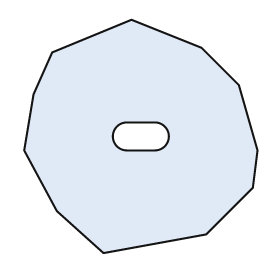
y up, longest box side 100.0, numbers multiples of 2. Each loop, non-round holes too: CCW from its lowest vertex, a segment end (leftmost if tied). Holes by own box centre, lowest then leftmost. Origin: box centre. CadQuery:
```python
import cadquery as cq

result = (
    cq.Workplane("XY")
    .moveTo(-16.0, -50.0)
    .lineTo(28.0, -42.0)
    .lineTo(48.0, -22.0)
    .lineTo(50.0, -6.0)
    .lineTo(42.0, 22.0)
    .lineTo(26.0, 38.0)
    .lineTo(-4.0, 50.0)
    .lineTo(-38.0, 36.0)
    .lineTo(-46.0, 18.0)
    .lineTo(-50.0, -6.0)
    .lineTo(-36.0, -32.0)
    .close()
    .moveTo(-6.0, -6.0)
    .lineTo(6.0, -6.0)
    .threePointArc((12.0, 0.0), (6.0, 6.0))
    .lineTo(-6.0, 6.0)
    .threePointArc((-12.0, 0.0), (-6.0, -6.0))
    .close()
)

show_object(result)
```